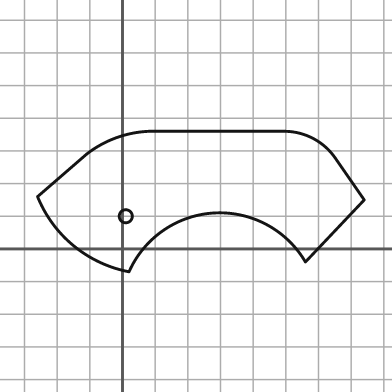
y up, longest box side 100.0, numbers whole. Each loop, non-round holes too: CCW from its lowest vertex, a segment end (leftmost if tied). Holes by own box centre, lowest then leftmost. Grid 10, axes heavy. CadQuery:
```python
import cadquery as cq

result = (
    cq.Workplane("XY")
    .moveTo(2.0, -7.0)
    .threePointArc((28.0, 11.0), (56.0, -4.0))
    .lineTo(74.0, 15.0)
    .lineTo(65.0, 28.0)
    .threePointArc((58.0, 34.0), (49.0, 36.0))
    .lineTo(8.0, 36.0)
    .threePointArc((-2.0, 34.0), (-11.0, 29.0))
    .lineTo(-26.0, 16.0)
    .threePointArc((-15.0, 1.0), (2.0, -7.0))
    .close()
    .moveTo(1.0, 10.0)
    .circle(2.0)
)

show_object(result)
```